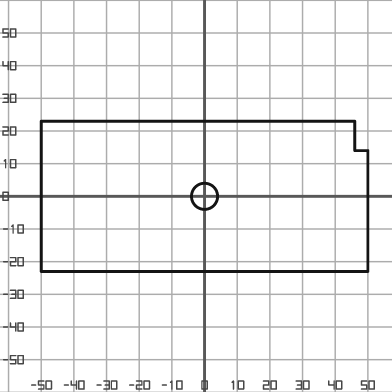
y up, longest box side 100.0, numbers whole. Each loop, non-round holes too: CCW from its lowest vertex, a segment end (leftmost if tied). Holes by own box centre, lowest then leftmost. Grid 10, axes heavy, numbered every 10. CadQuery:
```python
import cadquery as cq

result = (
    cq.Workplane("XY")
    .moveTo(-50.0, -23.0)
    .lineTo(50.0, -23.0)
    .lineTo(50.0, 14.0)
    .lineTo(46.0, 14.0)
    .lineTo(46.0, 23.0)
    .lineTo(-50.0, 23.0)
    .close()
    .moveTo(0.0, 0.0)
    .circle(4.0)
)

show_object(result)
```